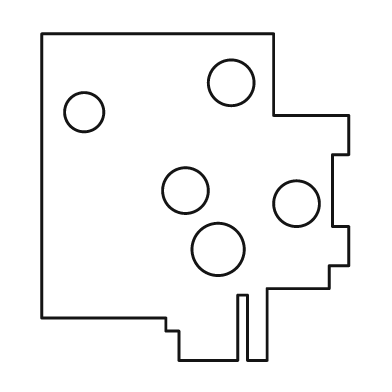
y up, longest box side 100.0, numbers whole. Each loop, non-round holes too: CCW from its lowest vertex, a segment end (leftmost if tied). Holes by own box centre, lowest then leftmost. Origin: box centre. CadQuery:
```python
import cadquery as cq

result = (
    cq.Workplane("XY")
    .moveTo(-5.0, -50.0)
    .lineTo(13.0, -50.0)
    .lineTo(13.0, -30.0)
    .lineTo(16.0, -30.0)
    .lineTo(16.0, -50.0)
    .lineTo(22.0, -50.0)
    .lineTo(22.0, -28.0)
    .lineTo(41.0, -28.0)
    .lineTo(41.0, -21.0)
    .lineTo(47.0, -21.0)
    .lineTo(47.0, -9.0)
    .lineTo(42.0, -9.0)
    .lineTo(42.0, 13.0)
    .lineTo(47.0, 13.0)
    .lineTo(47.0, 25.0)
    .lineTo(24.0, 25.0)
    .lineTo(24.0, 50.0)
    .lineTo(-47.0, 50.0)
    .lineTo(-47.0, -37.0)
    .lineTo(-9.0, -37.0)
    .lineTo(-9.0, -41.0)
    .lineTo(-5.0, -41.0)
    .close()
    .moveTo(7.0, -16.0)
    .circle(8.0)
    .moveTo(31.0, -2.0)
    .circle(7.0)
    .moveTo(-3.0, 2.0)
    .circle(7.0)
    .moveTo(-34.0, 26.0)
    .circle(6.0)
    .moveTo(11.0, 35.0)
    .circle(7.0)
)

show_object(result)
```